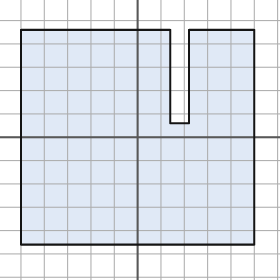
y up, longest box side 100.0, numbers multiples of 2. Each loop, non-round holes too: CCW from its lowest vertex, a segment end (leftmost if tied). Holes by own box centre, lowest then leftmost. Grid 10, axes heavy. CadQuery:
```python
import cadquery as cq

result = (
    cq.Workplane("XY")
    .moveTo(-50.0, -46.0)
    .lineTo(50.0, -46.0)
    .lineTo(50.0, 46.0)
    .lineTo(22.0, 46.0)
    .lineTo(22.0, 6.0)
    .lineTo(14.0, 6.0)
    .lineTo(14.0, 46.0)
    .lineTo(-50.0, 46.0)
    .close()
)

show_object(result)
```